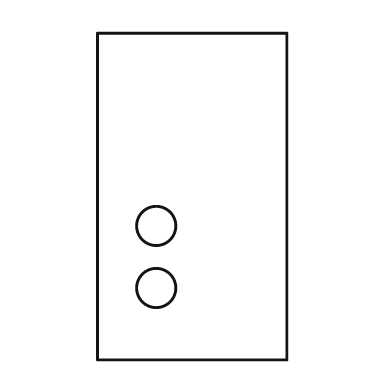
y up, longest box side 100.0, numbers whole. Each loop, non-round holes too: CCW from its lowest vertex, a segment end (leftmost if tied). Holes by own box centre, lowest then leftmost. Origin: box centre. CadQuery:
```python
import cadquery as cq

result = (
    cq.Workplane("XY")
    .moveTo(-29.0, -50.0)
    .lineTo(29.0, -50.0)
    .lineTo(29.0, 50.0)
    .lineTo(-29.0, 50.0)
    .close()
    .moveTo(-11.0, -28.0)
    .circle(6.0)
    .moveTo(-11.0, -9.0)
    .circle(6.0)
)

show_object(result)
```